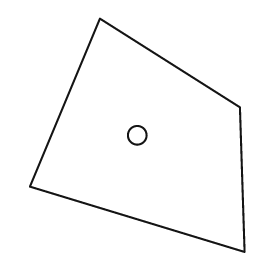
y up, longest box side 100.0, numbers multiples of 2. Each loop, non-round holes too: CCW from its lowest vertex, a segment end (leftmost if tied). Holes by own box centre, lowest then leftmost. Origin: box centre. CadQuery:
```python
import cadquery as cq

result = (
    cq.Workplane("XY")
    .moveTo(46.0, -50.0)
    .lineTo(44.0, 12.0)
    .lineTo(-16.0, 50.0)
    .lineTo(-46.0, -22.0)
    .close()
    .moveTo(0.0, 0.0)
    .circle(4.0)
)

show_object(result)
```